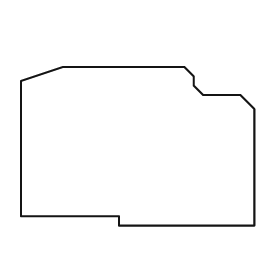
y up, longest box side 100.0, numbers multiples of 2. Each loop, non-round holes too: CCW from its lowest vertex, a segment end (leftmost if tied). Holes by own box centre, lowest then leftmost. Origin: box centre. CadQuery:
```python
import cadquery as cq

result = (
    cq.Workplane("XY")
    .moveTo(-8.0, -34.0)
    .lineTo(50.0, -34.0)
    .lineTo(50.0, 16.0)
    .lineTo(44.0, 22.0)
    .lineTo(28.0, 22.0)
    .lineTo(24.0, 26.0)
    .lineTo(24.0, 30.0)
    .lineTo(20.0, 34.0)
    .lineTo(-32.0, 34.0)
    .lineTo(-50.0, 28.0)
    .lineTo(-50.0, -30.0)
    .lineTo(-8.0, -30.0)
    .close()
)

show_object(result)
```